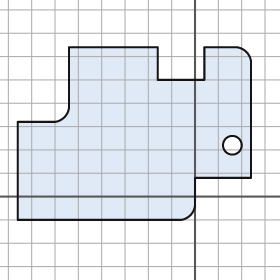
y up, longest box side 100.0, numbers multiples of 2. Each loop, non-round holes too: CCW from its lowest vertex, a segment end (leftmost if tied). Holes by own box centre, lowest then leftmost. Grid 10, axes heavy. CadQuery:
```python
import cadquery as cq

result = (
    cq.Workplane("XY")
    .moveTo(-76.0, -10.0)
    .lineTo(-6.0, -10.0)
    .threePointArc((-2.0, -8.0), (0.0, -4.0))
    .lineTo(0.0, 8.0)
    .lineTo(24.0, 8.0)
    .lineTo(24.0, 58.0)
    .threePointArc((22.0, 62.0), (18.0, 64.0))
    .lineTo(4.0, 64.0)
    .lineTo(4.0, 50.0)
    .lineTo(-16.0, 50.0)
    .lineTo(-16.0, 64.0)
    .lineTo(-54.0, 64.0)
    .lineTo(-54.0, 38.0)
    .threePointArc((-56.0, 34.0), (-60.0, 32.0))
    .lineTo(-76.0, 32.0)
    .close()
    .moveTo(16.0, 22.0)
    .circle(4.0)
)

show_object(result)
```